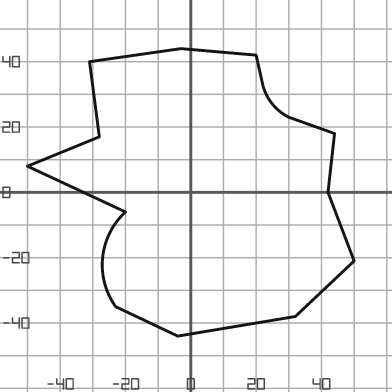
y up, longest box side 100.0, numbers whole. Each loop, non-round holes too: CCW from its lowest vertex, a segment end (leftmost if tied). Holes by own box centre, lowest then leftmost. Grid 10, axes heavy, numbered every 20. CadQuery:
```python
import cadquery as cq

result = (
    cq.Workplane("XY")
    .moveTo(-4.0, -44.0)
    .lineTo(32.0, -38.0)
    .lineTo(50.0, -21.0)
    .lineTo(42.0, 0.0)
    .lineTo(44.0, 18.0)
    .lineTo(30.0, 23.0)
    .threePointArc((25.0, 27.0), (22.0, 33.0))
    .lineTo(20.0, 42.0)
    .lineTo(-3.0, 44.0)
    .lineTo(-31.0, 40.0)
    .lineTo(-28.0, 17.0)
    .lineTo(-50.0, 8.0)
    .lineTo(-20.0, -6.0)
    .threePointArc((-27.0, -20.0), (-23.0, -35.0))
    .close()
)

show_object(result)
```